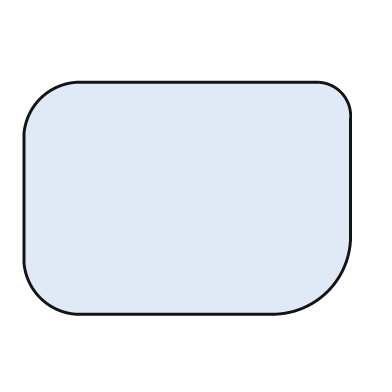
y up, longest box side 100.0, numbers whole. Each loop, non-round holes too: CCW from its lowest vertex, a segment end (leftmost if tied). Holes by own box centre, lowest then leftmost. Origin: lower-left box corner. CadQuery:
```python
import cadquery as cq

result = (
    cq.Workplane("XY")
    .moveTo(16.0, 0.0)
    .lineTo(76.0, 0.0)
    .threePointArc((93.0, 7.0), (100.0, 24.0))
    .lineTo(100.0, 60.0)
    .threePointArc((97.0, 68.0), (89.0, 71.0))
    .lineTo(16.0, 71.0)
    .threePointArc((5.0, 66.0), (0.0, 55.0))
    .lineTo(0.0, 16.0)
    .threePointArc((5.0, 5.0), (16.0, 0.0))
    .close()
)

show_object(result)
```